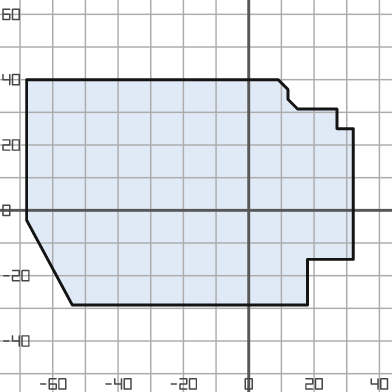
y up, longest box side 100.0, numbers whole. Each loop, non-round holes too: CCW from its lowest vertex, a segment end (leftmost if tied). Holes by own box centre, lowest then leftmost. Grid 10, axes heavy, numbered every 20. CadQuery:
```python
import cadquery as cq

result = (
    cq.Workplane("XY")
    .moveTo(-54.0, -29.0)
    .lineTo(18.0, -29.0)
    .lineTo(18.0, -15.0)
    .lineTo(32.0, -15.0)
    .lineTo(32.0, 25.0)
    .lineTo(27.0, 25.0)
    .lineTo(27.0, 31.0)
    .lineTo(15.0, 31.0)
    .lineTo(12.0, 34.0)
    .lineTo(12.0, 37.0)
    .lineTo(9.0, 40.0)
    .lineTo(-68.0, 40.0)
    .lineTo(-68.0, -3.0)
    .close()
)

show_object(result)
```